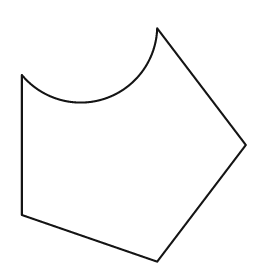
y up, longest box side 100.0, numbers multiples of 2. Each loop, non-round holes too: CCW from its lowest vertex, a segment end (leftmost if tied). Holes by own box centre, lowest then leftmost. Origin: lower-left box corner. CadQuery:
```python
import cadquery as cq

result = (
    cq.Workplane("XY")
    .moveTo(58.0, 0.0)
    .lineTo(96.0, 50.0)
    .lineTo(58.0, 100.0)
    .threePointArc((36.0, 70.0), (0.0, 80.0))
    .lineTo(0.0, 20.0)
    .close()
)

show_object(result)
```